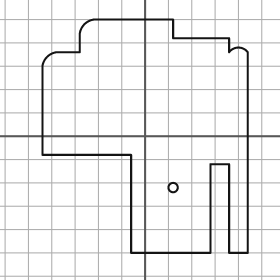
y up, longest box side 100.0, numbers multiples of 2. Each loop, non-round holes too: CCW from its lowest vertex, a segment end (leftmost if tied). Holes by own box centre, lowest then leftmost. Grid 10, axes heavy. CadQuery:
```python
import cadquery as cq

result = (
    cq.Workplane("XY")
    .moveTo(-6.0, -50.0)
    .lineTo(28.0, -50.0)
    .lineTo(28.0, -12.0)
    .lineTo(36.0, -12.0)
    .lineTo(36.0, -50.0)
    .lineTo(44.0, -50.0)
    .lineTo(44.0, 36.0)
    .threePointArc((40.0, 38.0), (36.0, 36.0))
    .lineTo(36.0, 42.0)
    .lineTo(12.0, 42.0)
    .lineTo(12.0, 50.0)
    .lineTo(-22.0, 50.0)
    .threePointArc((-26.0, 48.0), (-28.0, 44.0))
    .lineTo(-28.0, 36.0)
    .lineTo(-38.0, 36.0)
    .threePointArc((-42.0, 34.0), (-44.0, 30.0))
    .lineTo(-44.0, -8.0)
    .lineTo(-6.0, -8.0)
    .close()
    .moveTo(12.0, -22.0)
    .circle(2.0)
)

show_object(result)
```